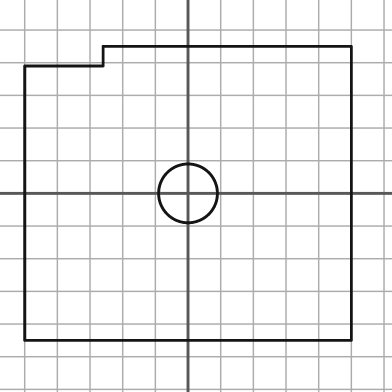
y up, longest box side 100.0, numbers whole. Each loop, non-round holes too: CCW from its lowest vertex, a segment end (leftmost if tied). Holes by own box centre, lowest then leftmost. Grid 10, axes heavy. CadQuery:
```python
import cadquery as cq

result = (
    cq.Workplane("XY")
    .moveTo(-50.0, -45.0)
    .lineTo(50.0, -45.0)
    .lineTo(50.0, 45.0)
    .lineTo(-26.0, 45.0)
    .lineTo(-26.0, 39.0)
    .lineTo(-50.0, 39.0)
    .close()
    .moveTo(0.0, 0.0)
    .circle(9.0)
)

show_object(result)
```